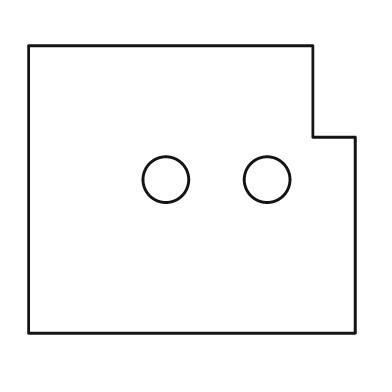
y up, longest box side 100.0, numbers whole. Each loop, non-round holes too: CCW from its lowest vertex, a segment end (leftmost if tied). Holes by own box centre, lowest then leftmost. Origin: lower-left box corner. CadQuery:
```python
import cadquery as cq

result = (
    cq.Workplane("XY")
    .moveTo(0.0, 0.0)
    .lineTo(100.0, 0.0)
    .lineTo(100.0, 60.0)
    .lineTo(87.0, 60.0)
    .lineTo(87.0, 88.0)
    .lineTo(0.0, 88.0)
    .close()
    .moveTo(42.0, 47.0)
    .circle(7.0)
    .moveTo(73.0, 47.0)
    .circle(7.0)
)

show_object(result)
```